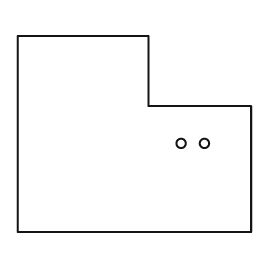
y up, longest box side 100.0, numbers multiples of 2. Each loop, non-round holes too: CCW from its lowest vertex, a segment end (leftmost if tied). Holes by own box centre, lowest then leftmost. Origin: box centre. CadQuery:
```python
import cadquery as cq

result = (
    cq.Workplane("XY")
    .moveTo(-50.0, -42.0)
    .lineTo(50.0, -42.0)
    .lineTo(50.0, 12.0)
    .lineTo(6.0, 12.0)
    .lineTo(6.0, 42.0)
    .lineTo(-50.0, 42.0)
    .close()
    .moveTo(20.0, -4.0)
    .circle(2.0)
    .moveTo(30.0, -4.0)
    .circle(2.0)
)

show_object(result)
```